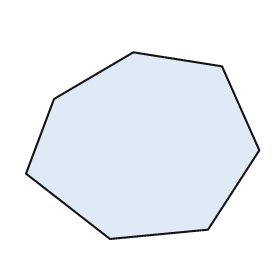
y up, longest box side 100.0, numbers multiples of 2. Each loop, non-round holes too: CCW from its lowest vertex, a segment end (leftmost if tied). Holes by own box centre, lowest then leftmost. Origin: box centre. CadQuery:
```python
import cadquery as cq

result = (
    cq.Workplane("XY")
    .moveTo(-14.0, -40.0)
    .lineTo(28.0, -36.0)
    .lineTo(50.0, -2.0)
    .lineTo(34.0, 34.0)
    .lineTo(-4.0, 40.0)
    .lineTo(-38.0, 20.0)
    .lineTo(-50.0, -12.0)
    .close()
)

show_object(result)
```